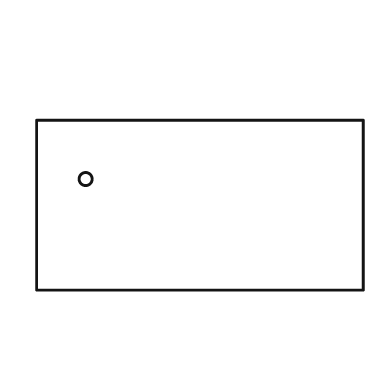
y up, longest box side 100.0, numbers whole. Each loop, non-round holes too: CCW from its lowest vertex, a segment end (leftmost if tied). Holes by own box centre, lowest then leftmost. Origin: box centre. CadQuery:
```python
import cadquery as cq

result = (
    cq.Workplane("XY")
    .moveTo(-50.0, -26.0)
    .lineTo(50.0, -26.0)
    .lineTo(50.0, 26.0)
    .lineTo(-50.0, 26.0)
    .close()
    .moveTo(-35.0, 8.0)
    .circle(2.0)
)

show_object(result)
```